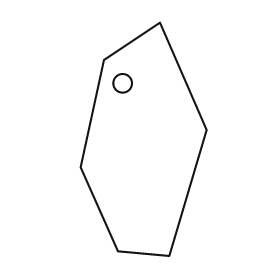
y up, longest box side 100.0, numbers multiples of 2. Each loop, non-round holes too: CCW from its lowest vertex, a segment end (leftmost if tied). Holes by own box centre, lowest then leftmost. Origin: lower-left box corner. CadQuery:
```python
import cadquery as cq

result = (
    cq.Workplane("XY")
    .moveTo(38.0, 0.0)
    .lineTo(54.0, 54.0)
    .lineTo(34.0, 100.0)
    .lineTo(10.0, 84.0)
    .lineTo(0.0, 38.0)
    .lineTo(16.0, 2.0)
    .close()
    .moveTo(18.0, 74.0)
    .circle(4.0)
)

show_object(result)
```